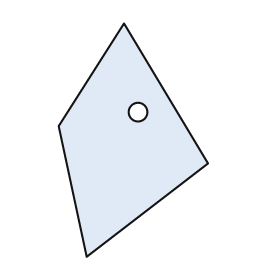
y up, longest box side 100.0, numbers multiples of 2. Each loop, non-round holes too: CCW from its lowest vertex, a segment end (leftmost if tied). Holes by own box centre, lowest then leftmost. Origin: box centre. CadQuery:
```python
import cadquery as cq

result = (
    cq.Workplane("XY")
    .moveTo(-20.0, -50.0)
    .lineTo(32.0, -10.0)
    .lineTo(-4.0, 50.0)
    .lineTo(-32.0, 6.0)
    .close()
    .moveTo(2.0, 12.0)
    .circle(4.0)
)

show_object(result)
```